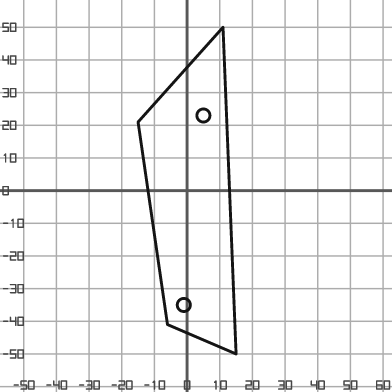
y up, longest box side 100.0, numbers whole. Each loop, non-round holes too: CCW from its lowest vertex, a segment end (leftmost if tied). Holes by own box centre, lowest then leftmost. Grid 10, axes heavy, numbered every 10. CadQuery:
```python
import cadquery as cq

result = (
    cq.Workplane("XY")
    .moveTo(15.0, -50.0)
    .lineTo(11.0, 50.0)
    .lineTo(-15.0, 21.0)
    .lineTo(-6.0, -41.0)
    .close()
    .moveTo(-1.0, -35.0)
    .circle(2.0)
    .moveTo(5.0, 23.0)
    .circle(2.0)
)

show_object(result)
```